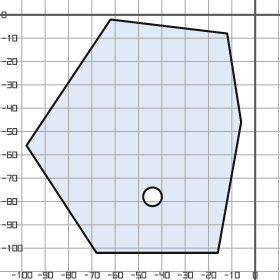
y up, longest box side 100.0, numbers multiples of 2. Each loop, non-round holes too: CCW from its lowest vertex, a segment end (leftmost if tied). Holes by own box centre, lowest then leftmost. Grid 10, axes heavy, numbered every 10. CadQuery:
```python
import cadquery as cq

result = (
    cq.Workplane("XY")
    .moveTo(-68.0, -102.0)
    .lineTo(-16.0, -102.0)
    .lineTo(-6.0, -46.0)
    .lineTo(-12.0, -8.0)
    .lineTo(-62.0, -2.0)
    .lineTo(-98.0, -56.0)
    .close()
    .moveTo(-44.0, -78.0)
    .circle(4.0)
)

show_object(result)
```